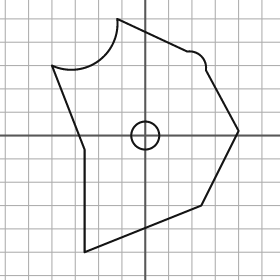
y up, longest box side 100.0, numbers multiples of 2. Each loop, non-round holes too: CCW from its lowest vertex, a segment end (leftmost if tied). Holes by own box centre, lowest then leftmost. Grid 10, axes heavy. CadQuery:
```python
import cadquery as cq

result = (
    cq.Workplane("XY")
    .moveTo(-26.0, -50.0)
    .lineTo(24.0, -30.0)
    .lineTo(40.0, 2.0)
    .lineTo(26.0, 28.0)
    .threePointArc((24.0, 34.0), (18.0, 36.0))
    .lineTo(-12.0, 50.0)
    .threePointArc((-20.0, 32.0), (-40.0, 30.0))
    .lineTo(-26.0, -6.0)
    .close()
    .moveTo(0.0, 0.0)
    .circle(6.0)
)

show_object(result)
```